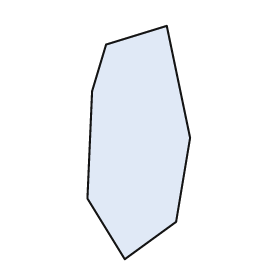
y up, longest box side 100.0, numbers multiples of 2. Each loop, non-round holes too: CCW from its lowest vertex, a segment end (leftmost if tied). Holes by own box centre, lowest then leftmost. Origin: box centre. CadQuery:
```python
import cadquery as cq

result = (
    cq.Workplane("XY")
    .moveTo(-6.0, -50.0)
    .lineTo(16.0, -34.0)
    .lineTo(22.0, 2.0)
    .lineTo(12.0, 50.0)
    .lineTo(-14.0, 42.0)
    .lineTo(-20.0, 22.0)
    .lineTo(-22.0, -24.0)
    .close()
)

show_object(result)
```